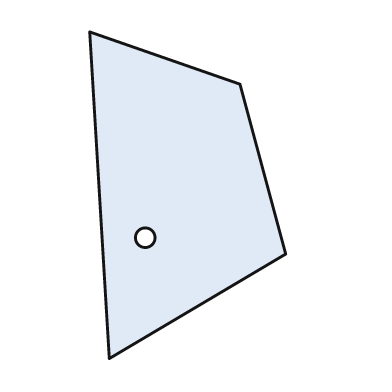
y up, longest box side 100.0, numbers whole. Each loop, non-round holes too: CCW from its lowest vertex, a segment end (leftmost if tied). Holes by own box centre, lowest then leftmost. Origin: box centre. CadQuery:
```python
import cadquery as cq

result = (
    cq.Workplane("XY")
    .moveTo(-24.0, -50.0)
    .lineTo(30.0, -18.0)
    .lineTo(16.0, 34.0)
    .lineTo(-30.0, 50.0)
    .close()
    .moveTo(-13.0, -13.0)
    .circle(3.0)
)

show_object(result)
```